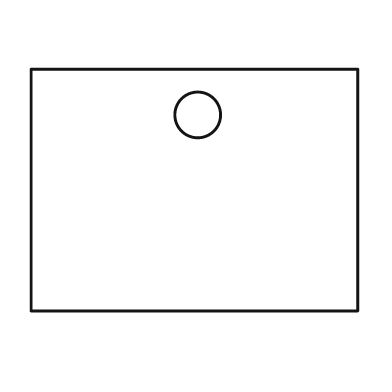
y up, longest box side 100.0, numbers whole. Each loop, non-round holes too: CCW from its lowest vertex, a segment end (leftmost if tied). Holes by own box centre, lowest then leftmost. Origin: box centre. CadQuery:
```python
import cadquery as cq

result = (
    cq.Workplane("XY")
    .moveTo(-50.0, -37.0)
    .lineTo(50.0, -37.0)
    .lineTo(50.0, 37.0)
    .lineTo(-50.0, 37.0)
    .close()
    .moveTo(1.0, 23.0)
    .circle(7.0)
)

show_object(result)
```